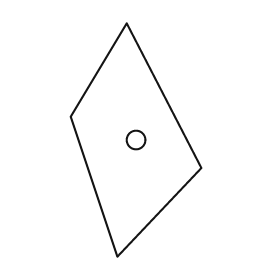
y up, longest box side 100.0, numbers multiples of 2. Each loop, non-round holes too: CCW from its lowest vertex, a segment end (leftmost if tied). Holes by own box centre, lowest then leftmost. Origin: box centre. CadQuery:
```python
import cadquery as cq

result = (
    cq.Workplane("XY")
    .moveTo(-8.0, -50.0)
    .lineTo(28.0, -12.0)
    .lineTo(-4.0, 50.0)
    .lineTo(-28.0, 10.0)
    .close()
    .moveTo(0.0, 0.0)
    .circle(4.0)
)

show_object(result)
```